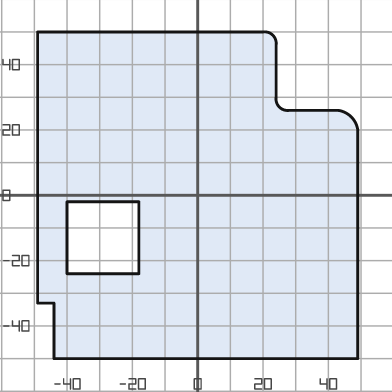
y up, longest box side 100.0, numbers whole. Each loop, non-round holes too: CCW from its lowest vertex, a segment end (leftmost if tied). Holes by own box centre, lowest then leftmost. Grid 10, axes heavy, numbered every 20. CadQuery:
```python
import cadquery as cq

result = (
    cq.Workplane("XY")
    .moveTo(-44.0, -50.0)
    .lineTo(49.0, -50.0)
    .lineTo(49.0, 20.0)
    .threePointArc((47.0, 24.0), (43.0, 26.0))
    .lineTo(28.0, 26.0)
    .threePointArc((25.0, 27.0), (24.0, 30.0))
    .lineTo(24.0, 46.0)
    .threePointArc((23.0, 49.0), (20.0, 50.0))
    .lineTo(-49.0, 50.0)
    .lineTo(-49.0, -33.0)
    .lineTo(-44.0, -33.0)
    .close()
    .moveTo(-40.0, -24.0)
    .lineTo(-18.0, -24.0)
    .lineTo(-18.0, -2.0)
    .lineTo(-40.0, -2.0)
    .close()
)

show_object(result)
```